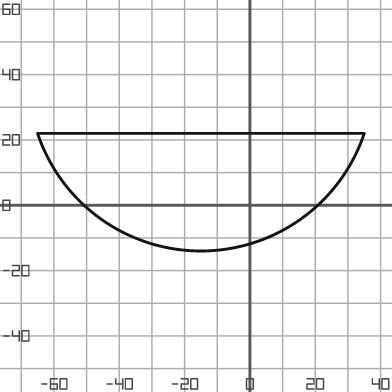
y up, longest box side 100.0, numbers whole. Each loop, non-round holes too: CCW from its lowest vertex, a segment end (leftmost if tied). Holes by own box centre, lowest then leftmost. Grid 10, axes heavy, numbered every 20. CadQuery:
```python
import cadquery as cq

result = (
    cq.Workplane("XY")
    .moveTo(-65.0, 22.0)
    .threePointArc((-15.0, -14.0), (35.0, 22.0))
    .close()
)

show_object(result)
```